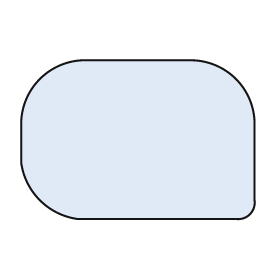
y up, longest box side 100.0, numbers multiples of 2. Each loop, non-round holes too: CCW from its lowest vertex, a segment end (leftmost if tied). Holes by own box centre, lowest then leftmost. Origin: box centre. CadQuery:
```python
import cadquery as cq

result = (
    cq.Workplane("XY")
    .moveTo(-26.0, -34.0)
    .lineTo(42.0, -34.0)
    .threePointArc((48.0, -32.0), (50.0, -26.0))
    .lineTo(50.0, 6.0)
    .threePointArc((42.0, 26.0), (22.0, 34.0))
    .lineTo(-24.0, 34.0)
    .threePointArc((-42.0, 26.0), (-50.0, 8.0))
    .lineTo(-50.0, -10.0)
    .threePointArc((-42.0, -26.0), (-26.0, -34.0))
    .close()
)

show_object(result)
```